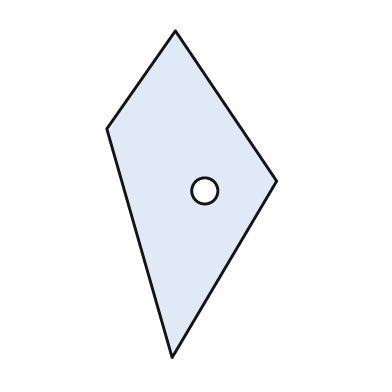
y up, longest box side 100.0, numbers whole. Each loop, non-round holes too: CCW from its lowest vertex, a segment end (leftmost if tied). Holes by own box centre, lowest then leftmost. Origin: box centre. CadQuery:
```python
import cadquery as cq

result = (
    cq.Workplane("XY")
    .moveTo(-6.0, -50.0)
    .lineTo(26.0, 4.0)
    .lineTo(-5.0, 50.0)
    .lineTo(-26.0, 20.0)
    .close()
    .moveTo(4.0, 1.0)
    .circle(4.0)
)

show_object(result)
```